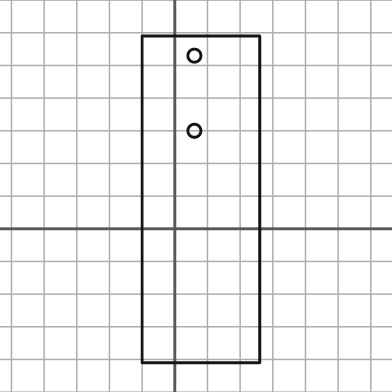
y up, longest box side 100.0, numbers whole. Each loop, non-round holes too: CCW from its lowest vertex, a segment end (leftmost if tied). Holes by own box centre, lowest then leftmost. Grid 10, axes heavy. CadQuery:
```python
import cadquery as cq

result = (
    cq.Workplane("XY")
    .moveTo(-10.0, -41.0)
    .lineTo(26.0, -41.0)
    .lineTo(26.0, 59.0)
    .lineTo(-10.0, 59.0)
    .close()
    .moveTo(6.0, 30.0)
    .circle(2.0)
    .moveTo(6.0, 53.0)
    .circle(2.0)
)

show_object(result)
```